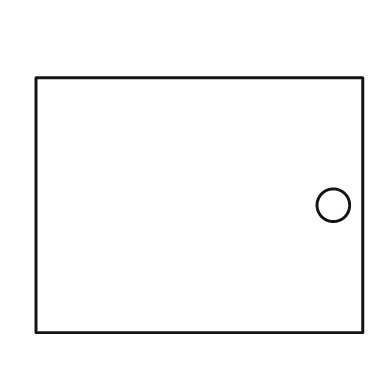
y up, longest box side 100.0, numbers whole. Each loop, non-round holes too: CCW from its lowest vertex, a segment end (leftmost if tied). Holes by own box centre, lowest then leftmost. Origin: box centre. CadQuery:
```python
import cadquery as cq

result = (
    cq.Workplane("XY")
    .moveTo(-50.0, -39.0)
    .lineTo(50.0, -39.0)
    .lineTo(50.0, 39.0)
    .lineTo(-50.0, 39.0)
    .close()
    .moveTo(41.0, 0.0)
    .circle(5.0)
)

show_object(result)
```